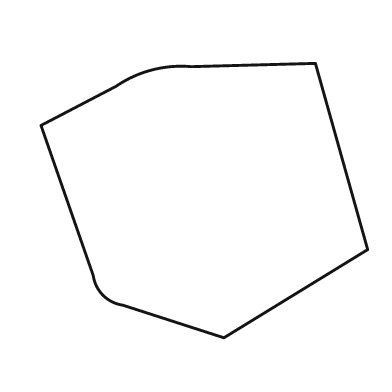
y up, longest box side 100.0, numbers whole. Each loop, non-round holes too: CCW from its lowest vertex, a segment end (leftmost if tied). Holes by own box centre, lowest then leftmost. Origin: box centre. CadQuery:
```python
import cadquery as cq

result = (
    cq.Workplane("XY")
    .moveTo(6.0, -42.0)
    .lineTo(50.0, -15.0)
    .lineTo(34.0, 42.0)
    .lineTo(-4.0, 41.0)
    .threePointArc((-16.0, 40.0), (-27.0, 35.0))
    .lineTo(-50.0, 23.0)
    .lineTo(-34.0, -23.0)
    .threePointArc((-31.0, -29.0), (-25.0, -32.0))
    .close()
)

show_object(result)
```